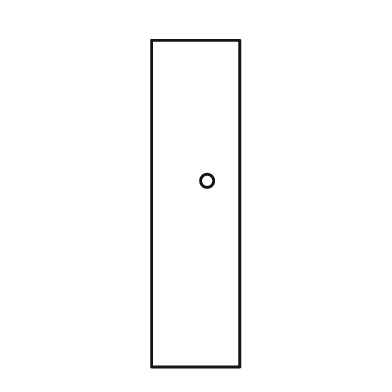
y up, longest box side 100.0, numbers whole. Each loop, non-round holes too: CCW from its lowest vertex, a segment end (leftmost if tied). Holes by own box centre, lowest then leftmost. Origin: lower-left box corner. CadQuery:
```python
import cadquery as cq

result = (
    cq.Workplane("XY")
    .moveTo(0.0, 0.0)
    .lineTo(27.0, 0.0)
    .lineTo(27.0, 100.0)
    .lineTo(0.0, 100.0)
    .close()
    .moveTo(17.0, 57.0)
    .circle(2.0)
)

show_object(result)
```